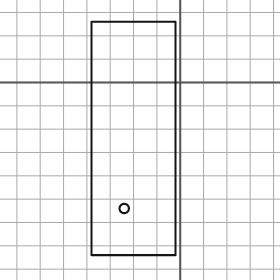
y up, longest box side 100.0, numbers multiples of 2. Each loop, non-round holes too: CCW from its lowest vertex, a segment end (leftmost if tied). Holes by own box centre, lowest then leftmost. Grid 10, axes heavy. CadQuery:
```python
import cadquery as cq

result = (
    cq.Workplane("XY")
    .moveTo(-38.0, -74.0)
    .lineTo(-2.0, -74.0)
    .lineTo(-2.0, 26.0)
    .lineTo(-38.0, 26.0)
    .close()
    .moveTo(-24.0, -54.0)
    .circle(2.0)
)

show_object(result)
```